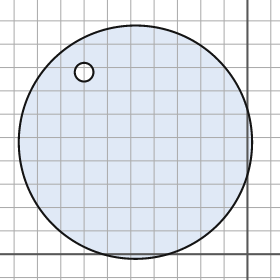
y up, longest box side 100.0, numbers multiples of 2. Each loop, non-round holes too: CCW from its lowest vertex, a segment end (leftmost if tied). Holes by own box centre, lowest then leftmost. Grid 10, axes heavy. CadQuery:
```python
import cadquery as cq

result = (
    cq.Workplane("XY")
    .moveTo(-48.0, 48.0)
    .circle(50.0)
    .moveTo(-70.0, 78.0)
    .circle(4.0)
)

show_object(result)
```